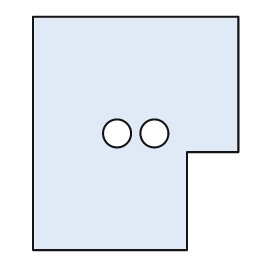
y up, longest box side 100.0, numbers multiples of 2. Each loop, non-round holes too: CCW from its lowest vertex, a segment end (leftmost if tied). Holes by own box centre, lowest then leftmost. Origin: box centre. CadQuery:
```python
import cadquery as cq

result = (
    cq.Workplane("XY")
    .moveTo(-44.0, -50.0)
    .lineTo(22.0, -50.0)
    .lineTo(22.0, -8.0)
    .lineTo(44.0, -8.0)
    .lineTo(44.0, 50.0)
    .lineTo(-44.0, 50.0)
    .close()
    .moveTo(-8.0, 0.0)
    .circle(6.0)
    .moveTo(8.0, 0.0)
    .circle(6.0)
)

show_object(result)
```